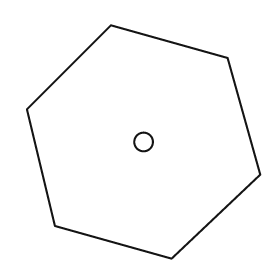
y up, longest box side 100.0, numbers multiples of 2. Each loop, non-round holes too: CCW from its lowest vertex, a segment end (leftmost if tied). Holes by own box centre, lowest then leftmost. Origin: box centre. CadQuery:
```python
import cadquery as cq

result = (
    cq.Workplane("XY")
    .moveTo(12.0, -50.0)
    .lineTo(50.0, -14.0)
    .lineTo(36.0, 36.0)
    .lineTo(-14.0, 50.0)
    .lineTo(-50.0, 14.0)
    .lineTo(-38.0, -36.0)
    .close()
    .moveTo(0.0, 0.0)
    .circle(4.0)
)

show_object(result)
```